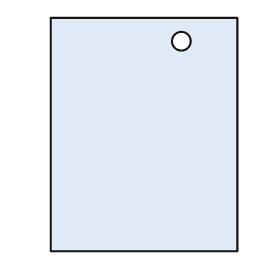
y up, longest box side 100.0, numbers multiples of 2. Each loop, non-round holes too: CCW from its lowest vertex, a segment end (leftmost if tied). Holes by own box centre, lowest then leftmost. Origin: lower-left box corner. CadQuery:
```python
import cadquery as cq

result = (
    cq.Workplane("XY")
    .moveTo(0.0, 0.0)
    .lineTo(80.0, 0.0)
    .lineTo(80.0, 100.0)
    .lineTo(0.0, 100.0)
    .close()
    .moveTo(56.0, 90.0)
    .circle(4.0)
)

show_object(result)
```